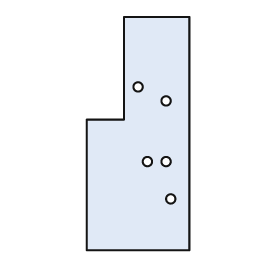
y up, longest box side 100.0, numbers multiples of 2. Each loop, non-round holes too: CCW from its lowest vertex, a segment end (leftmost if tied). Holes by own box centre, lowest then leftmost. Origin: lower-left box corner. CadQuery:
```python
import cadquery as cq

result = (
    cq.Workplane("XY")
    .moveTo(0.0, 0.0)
    .lineTo(44.0, 0.0)
    .lineTo(44.0, 100.0)
    .lineTo(16.0, 100.0)
    .lineTo(16.0, 56.0)
    .lineTo(0.0, 56.0)
    .close()
    .moveTo(36.0, 22.0)
    .circle(2.0)
    .moveTo(26.0, 38.0)
    .circle(2.0)
    .moveTo(34.0, 38.0)
    .circle(2.0)
    .moveTo(34.0, 64.0)
    .circle(2.0)
    .moveTo(22.0, 70.0)
    .circle(2.0)
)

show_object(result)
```